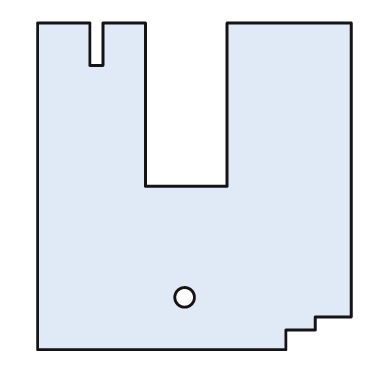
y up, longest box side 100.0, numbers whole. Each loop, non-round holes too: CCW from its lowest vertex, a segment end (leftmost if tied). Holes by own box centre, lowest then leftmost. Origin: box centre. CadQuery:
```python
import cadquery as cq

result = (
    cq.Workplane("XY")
    .moveTo(-48.0, -50.0)
    .lineTo(28.0, -50.0)
    .lineTo(28.0, -44.0)
    .lineTo(37.0, -44.0)
    .lineTo(37.0, -40.0)
    .lineTo(48.0, -40.0)
    .lineTo(48.0, 50.0)
    .lineTo(10.0, 50.0)
    .lineTo(10.0, 0.0)
    .lineTo(-15.0, 0.0)
    .lineTo(-15.0, 50.0)
    .lineTo(-28.0, 50.0)
    .lineTo(-28.0, 37.0)
    .lineTo(-32.0, 37.0)
    .lineTo(-32.0, 50.0)
    .lineTo(-48.0, 50.0)
    .close()
    .moveTo(-3.0, -34.0)
    .circle(3.0)
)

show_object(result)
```